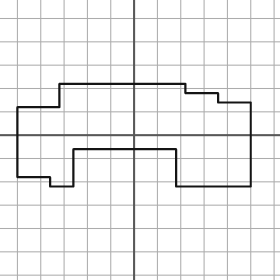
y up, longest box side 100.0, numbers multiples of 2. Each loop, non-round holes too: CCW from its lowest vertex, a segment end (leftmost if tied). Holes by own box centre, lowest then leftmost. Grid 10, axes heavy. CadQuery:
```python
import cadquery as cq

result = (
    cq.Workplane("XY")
    .moveTo(-36.0, -22.0)
    .lineTo(-26.0, -22.0)
    .lineTo(-26.0, -6.0)
    .lineTo(18.0, -6.0)
    .lineTo(18.0, -22.0)
    .lineTo(50.0, -22.0)
    .lineTo(50.0, 14.0)
    .lineTo(36.0, 14.0)
    .lineTo(36.0, 18.0)
    .lineTo(22.0, 18.0)
    .lineTo(22.0, 22.0)
    .lineTo(-32.0, 22.0)
    .lineTo(-32.0, 12.0)
    .lineTo(-50.0, 12.0)
    .lineTo(-50.0, -18.0)
    .lineTo(-36.0, -18.0)
    .close()
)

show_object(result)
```